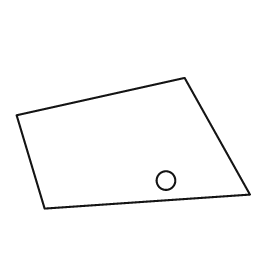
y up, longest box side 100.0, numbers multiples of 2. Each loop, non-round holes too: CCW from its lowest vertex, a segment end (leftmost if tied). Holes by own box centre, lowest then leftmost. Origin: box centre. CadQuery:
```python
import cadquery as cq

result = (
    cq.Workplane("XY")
    .moveTo(-38.0, -28.0)
    .lineTo(50.0, -22.0)
    .lineTo(22.0, 28.0)
    .lineTo(-50.0, 12.0)
    .close()
    .moveTo(14.0, -16.0)
    .circle(4.0)
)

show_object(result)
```